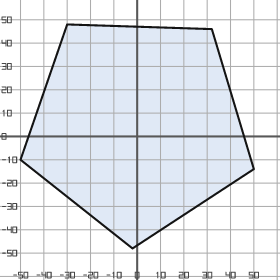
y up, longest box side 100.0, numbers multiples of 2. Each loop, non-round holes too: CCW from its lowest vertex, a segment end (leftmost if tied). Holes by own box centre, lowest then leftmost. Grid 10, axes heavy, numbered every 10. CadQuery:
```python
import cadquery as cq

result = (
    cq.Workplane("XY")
    .moveTo(-2.0, -48.0)
    .lineTo(50.0, -14.0)
    .lineTo(32.0, 46.0)
    .lineTo(-30.0, 48.0)
    .lineTo(-50.0, -10.0)
    .close()
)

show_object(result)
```